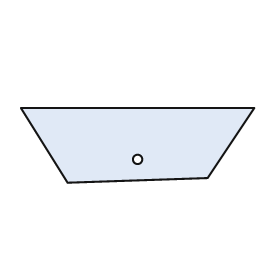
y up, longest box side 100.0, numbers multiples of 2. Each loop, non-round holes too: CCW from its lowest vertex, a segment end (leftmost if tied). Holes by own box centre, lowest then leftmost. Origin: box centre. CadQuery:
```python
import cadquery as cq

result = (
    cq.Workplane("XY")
    .moveTo(-30.0, -16.0)
    .lineTo(30.0, -14.0)
    .lineTo(50.0, 16.0)
    .lineTo(-50.0, 16.0)
    .close()
    .moveTo(0.0, -6.0)
    .circle(2.0)
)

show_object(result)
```